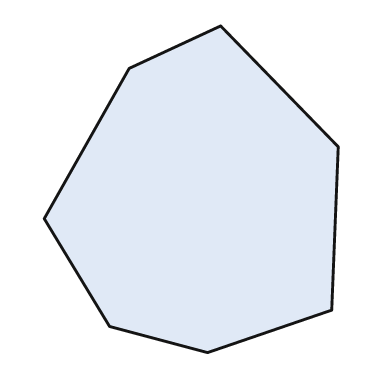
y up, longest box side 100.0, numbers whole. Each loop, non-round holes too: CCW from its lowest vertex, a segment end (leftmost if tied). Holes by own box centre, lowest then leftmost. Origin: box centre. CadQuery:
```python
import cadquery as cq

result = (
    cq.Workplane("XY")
    .moveTo(5.0, -50.0)
    .lineTo(43.0, -37.0)
    .lineTo(45.0, 13.0)
    .lineTo(9.0, 50.0)
    .lineTo(-19.0, 37.0)
    .lineTo(-45.0, -9.0)
    .lineTo(-25.0, -42.0)
    .close()
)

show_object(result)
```